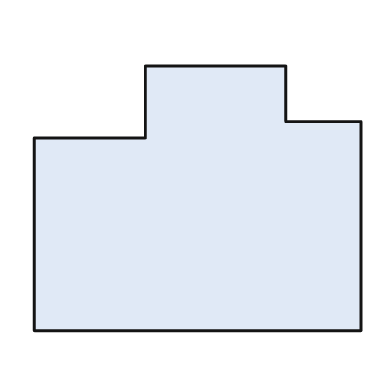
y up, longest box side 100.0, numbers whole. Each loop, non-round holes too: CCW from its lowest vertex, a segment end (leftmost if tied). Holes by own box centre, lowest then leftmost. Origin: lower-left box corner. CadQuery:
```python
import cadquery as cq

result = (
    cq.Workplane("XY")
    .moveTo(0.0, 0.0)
    .lineTo(100.0, 0.0)
    .lineTo(100.0, 64.0)
    .lineTo(77.0, 64.0)
    .lineTo(77.0, 81.0)
    .lineTo(34.0, 81.0)
    .lineTo(34.0, 59.0)
    .lineTo(0.0, 59.0)
    .close()
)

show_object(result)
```